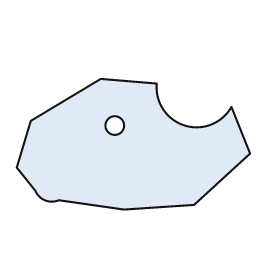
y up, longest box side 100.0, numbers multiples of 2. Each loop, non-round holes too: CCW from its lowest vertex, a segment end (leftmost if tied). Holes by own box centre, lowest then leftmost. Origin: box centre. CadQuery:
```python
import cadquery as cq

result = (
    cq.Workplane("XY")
    .moveTo(-4.0, -28.0)
    .lineTo(26.0, -26.0)
    .lineTo(50.0, -4.0)
    .lineTo(42.0, 16.0)
    .threePointArc((22.0, 8.0), (10.0, 26.0))
    .lineTo(-14.0, 28.0)
    .lineTo(-44.0, 10.0)
    .lineTo(-50.0, -10.0)
    .lineTo(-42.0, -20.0)
    .threePointArc((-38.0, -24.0), (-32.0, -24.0))
    .close()
    .moveTo(-8.0, 8.0)
    .circle(4.0)
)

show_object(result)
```